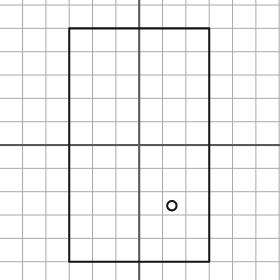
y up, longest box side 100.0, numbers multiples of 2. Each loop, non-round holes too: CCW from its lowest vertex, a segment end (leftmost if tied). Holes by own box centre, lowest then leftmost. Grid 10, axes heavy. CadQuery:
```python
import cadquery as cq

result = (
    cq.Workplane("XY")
    .moveTo(-30.0, -50.0)
    .lineTo(30.0, -50.0)
    .lineTo(30.0, 50.0)
    .lineTo(-30.0, 50.0)
    .close()
    .moveTo(14.0, -26.0)
    .circle(2.0)
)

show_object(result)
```